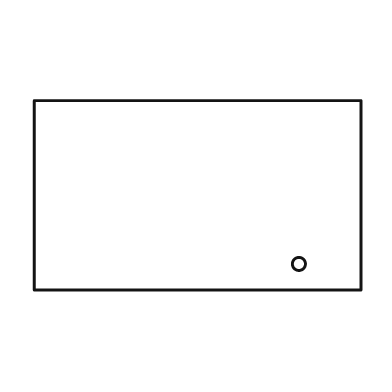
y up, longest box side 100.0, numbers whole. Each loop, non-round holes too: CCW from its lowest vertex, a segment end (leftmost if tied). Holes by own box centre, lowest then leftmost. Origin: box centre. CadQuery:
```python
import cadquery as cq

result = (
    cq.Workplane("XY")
    .moveTo(-50.0, -29.0)
    .lineTo(50.0, -29.0)
    .lineTo(50.0, 29.0)
    .lineTo(-50.0, 29.0)
    .close()
    .moveTo(31.0, -21.0)
    .circle(2.0)
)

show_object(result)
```